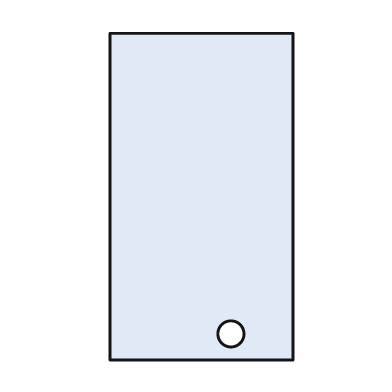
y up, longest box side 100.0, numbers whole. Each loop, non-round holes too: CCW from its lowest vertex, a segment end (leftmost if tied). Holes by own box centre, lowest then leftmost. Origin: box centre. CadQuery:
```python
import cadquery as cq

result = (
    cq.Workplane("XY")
    .moveTo(-28.0, -50.0)
    .lineTo(28.0, -50.0)
    .lineTo(28.0, 50.0)
    .lineTo(-28.0, 50.0)
    .close()
    .moveTo(9.0, -42.0)
    .circle(4.0)
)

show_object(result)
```